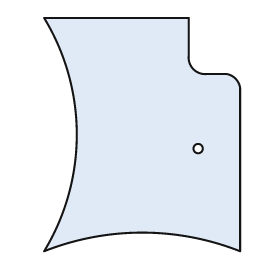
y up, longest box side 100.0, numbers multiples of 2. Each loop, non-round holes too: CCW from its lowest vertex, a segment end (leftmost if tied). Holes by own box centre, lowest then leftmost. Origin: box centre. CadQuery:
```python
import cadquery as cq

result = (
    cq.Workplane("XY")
    .moveTo(-42.0, -50.0)
    .threePointArc((0.0, -42.0), (42.0, -50.0))
    .lineTo(42.0, 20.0)
    .threePointArc((40.0, 24.0), (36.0, 26.0))
    .lineTo(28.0, 26.0)
    .threePointArc((22.0, 28.0), (20.0, 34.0))
    .lineTo(20.0, 50.0)
    .lineTo(-42.0, 50.0)
    .threePointArc((-28.0, 0.0), (-42.0, -50.0))
    .close()
    .moveTo(24.0, -6.0)
    .circle(2.0)
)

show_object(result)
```